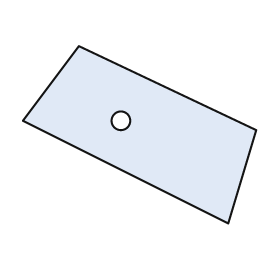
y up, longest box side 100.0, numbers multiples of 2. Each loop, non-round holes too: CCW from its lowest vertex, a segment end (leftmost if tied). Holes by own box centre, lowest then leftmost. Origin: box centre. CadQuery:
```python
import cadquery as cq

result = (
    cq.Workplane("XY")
    .moveTo(38.0, -38.0)
    .lineTo(50.0, 2.0)
    .lineTo(-26.0, 38.0)
    .lineTo(-50.0, 6.0)
    .close()
    .moveTo(-8.0, 6.0)
    .circle(4.0)
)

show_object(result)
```